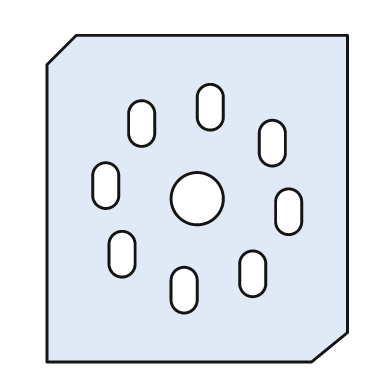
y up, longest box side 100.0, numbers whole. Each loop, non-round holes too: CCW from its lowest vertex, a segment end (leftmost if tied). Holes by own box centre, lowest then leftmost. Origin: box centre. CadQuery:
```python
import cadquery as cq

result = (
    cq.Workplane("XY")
    .moveTo(-46.0, -50.0)
    .lineTo(35.0, -50.0)
    .lineTo(46.0, -41.0)
    .lineTo(46.0, 50.0)
    .lineTo(-37.0, 50.0)
    .lineTo(-46.0, 41.0)
    .close()
    .moveTo(-8.0, -31.0)
    .threePointArc((-4.0, -35.0), (0.0, -31.0))
    .lineTo(0.0, -25.0)
    .threePointArc((-4.0, -21.0), (-8.0, -25.0))
    .close()
    .moveTo(13.0, -26.0)
    .threePointArc((17.0, -30.0), (21.0, -26.0))
    .lineTo(21.0, -20.0)
    .threePointArc((17.0, -16.0), (13.0, -20.0))
    .close()
    .moveTo(-27.0, -20.0)
    .threePointArc((-23.0, -24.0), (-19.0, -20.0))
    .lineTo(-19.0, -14.0)
    .threePointArc((-23.0, -10.0), (-27.0, -14.0))
    .close()
    .moveTo(24.0, -7.0)
    .threePointArc((28.0, -11.0), (32.0, -7.0))
    .lineTo(32.0, -1.0)
    .threePointArc((28.0, 3.0), (24.0, -1.0))
    .close()
    .moveTo(0.0, 0.0)
    .circle(8.0)
    .moveTo(-32.0, 1.0)
    .threePointArc((-28.0, -3.0), (-24.0, 1.0))
    .lineTo(-24.0, 7.0)
    .threePointArc((-28.0, 11.0), (-32.0, 7.0))
    .close()
    .moveTo(19.0, 14.0)
    .threePointArc((23.0, 10.0), (27.0, 14.0))
    .lineTo(27.0, 20.0)
    .threePointArc((23.0, 24.0), (19.0, 20.0))
    .close()
    .moveTo(-21.0, 20.0)
    .threePointArc((-17.0, 16.0), (-13.0, 20.0))
    .lineTo(-13.0, 26.0)
    .threePointArc((-17.0, 30.0), (-21.0, 26.0))
    .close()
    .moveTo(0.0, 25.0)
    .threePointArc((4.0, 21.0), (8.0, 25.0))
    .lineTo(8.0, 31.0)
    .threePointArc((4.0, 35.0), (0.0, 31.0))
    .close()
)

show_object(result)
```